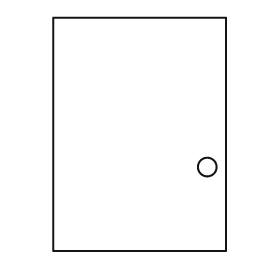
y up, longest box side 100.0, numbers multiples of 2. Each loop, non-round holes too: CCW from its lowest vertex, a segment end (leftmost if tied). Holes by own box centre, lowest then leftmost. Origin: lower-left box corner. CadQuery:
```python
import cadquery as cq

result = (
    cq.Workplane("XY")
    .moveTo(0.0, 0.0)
    .lineTo(74.0, 0.0)
    .lineTo(74.0, 100.0)
    .lineTo(0.0, 100.0)
    .close()
    .moveTo(66.0, 36.0)
    .circle(4.0)
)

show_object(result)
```